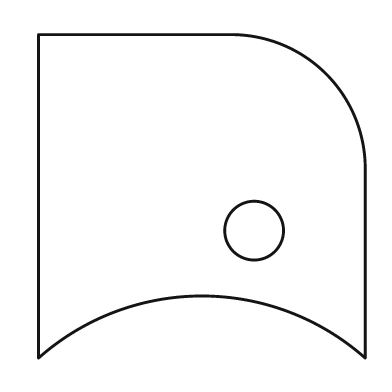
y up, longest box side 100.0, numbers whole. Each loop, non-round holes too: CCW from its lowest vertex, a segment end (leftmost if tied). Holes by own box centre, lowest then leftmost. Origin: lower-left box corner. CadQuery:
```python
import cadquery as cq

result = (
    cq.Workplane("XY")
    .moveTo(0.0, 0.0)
    .threePointArc((50.0, 19.0), (100.0, 0.0))
    .lineTo(100.0, 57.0)
    .threePointArc((88.0, 87.0), (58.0, 99.0))
    .lineTo(0.0, 99.0)
    .close()
    .moveTo(66.0, 39.0)
    .circle(9.0)
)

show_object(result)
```